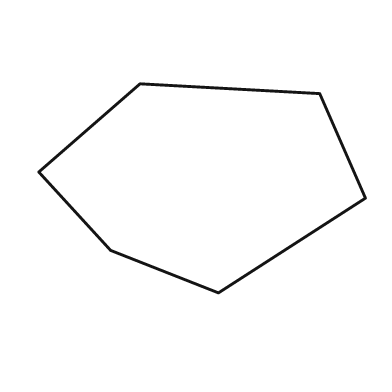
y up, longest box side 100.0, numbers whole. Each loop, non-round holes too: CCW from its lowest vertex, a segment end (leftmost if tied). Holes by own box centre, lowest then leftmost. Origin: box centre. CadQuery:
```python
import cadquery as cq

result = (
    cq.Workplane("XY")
    .moveTo(5.0, -32.0)
    .lineTo(50.0, -3.0)
    .lineTo(36.0, 29.0)
    .lineTo(-19.0, 32.0)
    .lineTo(-50.0, 5.0)
    .lineTo(-28.0, -19.0)
    .close()
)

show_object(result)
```